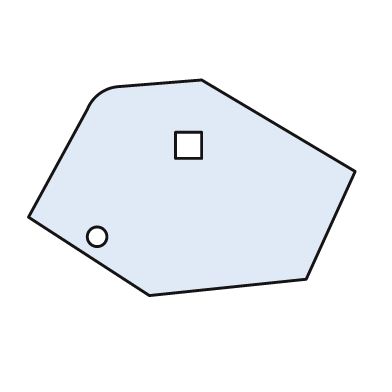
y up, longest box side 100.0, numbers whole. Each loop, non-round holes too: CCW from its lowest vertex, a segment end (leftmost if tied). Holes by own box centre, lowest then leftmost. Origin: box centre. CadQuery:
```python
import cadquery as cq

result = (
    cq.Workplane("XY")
    .moveTo(-13.0, -33.0)
    .lineTo(35.0, -28.0)
    .lineTo(50.0, 5.0)
    .lineTo(3.0, 33.0)
    .lineTo(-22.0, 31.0)
    .threePointArc((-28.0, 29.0), (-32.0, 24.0))
    .lineTo(-50.0, -9.0)
    .close()
    .moveTo(-29.0, -15.0)
    .circle(3.0)
    .moveTo(-5.0, 9.0)
    .lineTo(3.0, 9.0)
    .lineTo(3.0, 17.0)
    .lineTo(-5.0, 17.0)
    .close()
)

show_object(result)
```